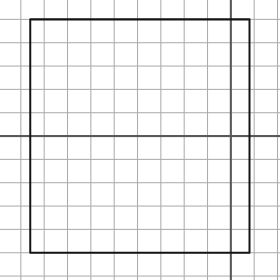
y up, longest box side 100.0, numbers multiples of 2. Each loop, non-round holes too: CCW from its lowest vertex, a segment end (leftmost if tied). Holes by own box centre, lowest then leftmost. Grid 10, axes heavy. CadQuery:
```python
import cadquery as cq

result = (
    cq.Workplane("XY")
    .moveTo(-86.0, -50.0)
    .lineTo(8.0, -50.0)
    .lineTo(8.0, 50.0)
    .lineTo(-86.0, 50.0)
    .close()
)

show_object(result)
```